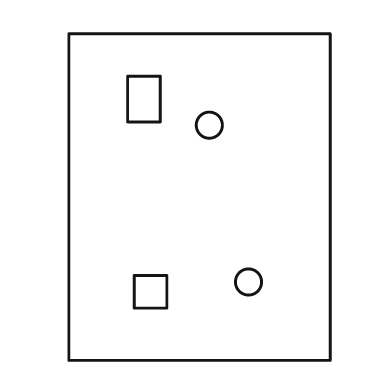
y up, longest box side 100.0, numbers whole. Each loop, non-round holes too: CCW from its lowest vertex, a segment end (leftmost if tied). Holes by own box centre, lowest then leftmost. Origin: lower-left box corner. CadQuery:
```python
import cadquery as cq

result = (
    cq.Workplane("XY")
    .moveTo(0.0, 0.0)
    .lineTo(80.0, 0.0)
    .lineTo(80.0, 100.0)
    .lineTo(0.0, 100.0)
    .close()
    .moveTo(20.0, 16.0)
    .lineTo(30.0, 16.0)
    .lineTo(30.0, 26.0)
    .lineTo(20.0, 26.0)
    .close()
    .moveTo(55.0, 24.0)
    .circle(4.0)
    .moveTo(43.0, 72.0)
    .circle(4.0)
    .moveTo(18.0, 73.0)
    .lineTo(28.0, 73.0)
    .lineTo(28.0, 87.0)
    .lineTo(18.0, 87.0)
    .close()
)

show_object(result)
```